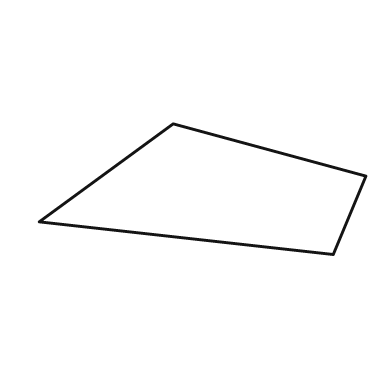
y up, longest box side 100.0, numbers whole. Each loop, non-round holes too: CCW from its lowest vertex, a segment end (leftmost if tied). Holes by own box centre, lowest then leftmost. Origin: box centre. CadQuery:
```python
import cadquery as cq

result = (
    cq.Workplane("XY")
    .moveTo(40.0, -20.0)
    .lineTo(50.0, 4.0)
    .lineTo(-9.0, 20.0)
    .lineTo(-50.0, -10.0)
    .close()
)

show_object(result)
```